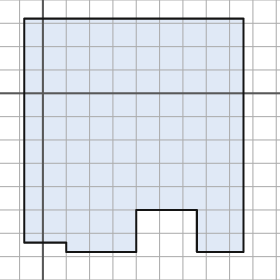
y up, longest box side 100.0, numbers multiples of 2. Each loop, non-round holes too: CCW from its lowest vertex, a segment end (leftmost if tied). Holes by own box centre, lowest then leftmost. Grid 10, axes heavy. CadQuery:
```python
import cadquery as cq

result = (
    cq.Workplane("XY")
    .moveTo(10.0, -68.0)
    .lineTo(40.0, -68.0)
    .lineTo(40.0, -50.0)
    .lineTo(66.0, -50.0)
    .lineTo(66.0, -68.0)
    .lineTo(86.0, -68.0)
    .lineTo(86.0, 32.0)
    .lineTo(-8.0, 32.0)
    .lineTo(-8.0, -64.0)
    .lineTo(10.0, -64.0)
    .close()
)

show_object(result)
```